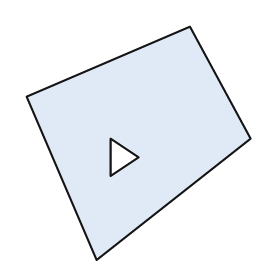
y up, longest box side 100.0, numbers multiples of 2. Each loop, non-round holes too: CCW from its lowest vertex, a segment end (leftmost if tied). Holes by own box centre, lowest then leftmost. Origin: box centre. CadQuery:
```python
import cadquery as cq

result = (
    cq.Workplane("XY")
    .moveTo(-18.0, -50.0)
    .lineTo(48.0, 2.0)
    .lineTo(22.0, 50.0)
    .lineTo(-48.0, 20.0)
    .close()
    .moveTo(-12.0, -14.0)
    .lineTo(0.0, -6.0)
    .lineTo(-12.0, 2.0)
    .close()
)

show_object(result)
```